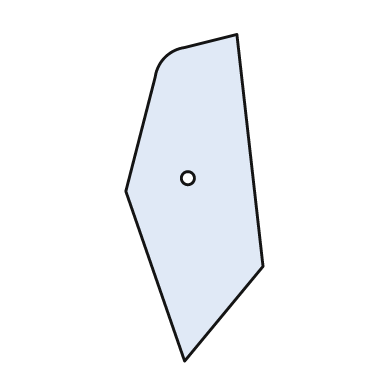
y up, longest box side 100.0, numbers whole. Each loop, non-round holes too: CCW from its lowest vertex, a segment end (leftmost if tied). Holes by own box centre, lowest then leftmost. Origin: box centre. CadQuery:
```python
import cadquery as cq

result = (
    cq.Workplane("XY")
    .moveTo(-3.0, -50.0)
    .lineTo(21.0, -21.0)
    .lineTo(13.0, 50.0)
    .lineTo(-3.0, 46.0)
    .threePointArc((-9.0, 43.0), (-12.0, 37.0))
    .lineTo(-21.0, 2.0)
    .close()
    .moveTo(-2.0, 6.0)
    .circle(2.0)
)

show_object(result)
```